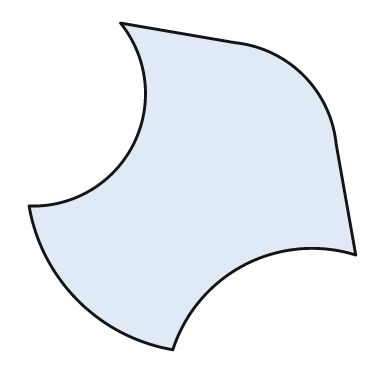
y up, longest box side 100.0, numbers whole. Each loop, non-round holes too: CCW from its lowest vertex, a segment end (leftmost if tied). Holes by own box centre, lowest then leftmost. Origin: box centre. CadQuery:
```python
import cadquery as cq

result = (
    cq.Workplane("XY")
    .moveTo(-6.0, -50.0)
    .threePointArc((16.0, -24.0), (50.0, -21.0))
    .lineTo(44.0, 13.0)
    .threePointArc((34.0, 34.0), (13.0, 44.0))
    .lineTo(-22.0, 50.0)
    .threePointArc((-18.0, 13.0), (-50.0, -6.0))
    .threePointArc((-35.0, -35.0), (-6.0, -50.0))
    .close()
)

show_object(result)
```